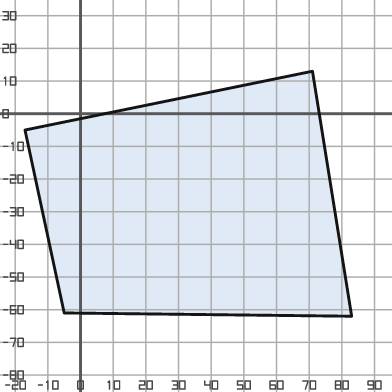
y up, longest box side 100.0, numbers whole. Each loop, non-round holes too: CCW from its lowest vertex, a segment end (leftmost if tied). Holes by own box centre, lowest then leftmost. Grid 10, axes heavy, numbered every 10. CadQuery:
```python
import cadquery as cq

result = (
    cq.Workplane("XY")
    .moveTo(83.0, -62.0)
    .lineTo(71.0, 13.0)
    .lineTo(-17.0, -5.0)
    .lineTo(-5.0, -61.0)
    .close()
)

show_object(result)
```